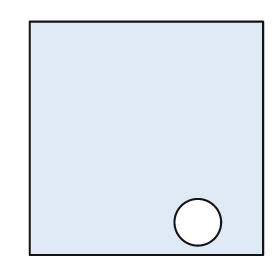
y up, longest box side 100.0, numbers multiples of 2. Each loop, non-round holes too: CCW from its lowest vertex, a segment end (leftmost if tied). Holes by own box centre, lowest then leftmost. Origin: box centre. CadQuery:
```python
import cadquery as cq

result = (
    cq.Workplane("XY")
    .moveTo(-50.0, -50.0)
    .lineTo(50.0, -50.0)
    .lineTo(50.0, 50.0)
    .lineTo(-50.0, 50.0)
    .close()
    .moveTo(22.0, -36.0)
    .circle(10.0)
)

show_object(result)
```